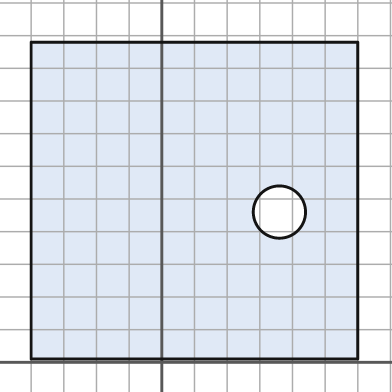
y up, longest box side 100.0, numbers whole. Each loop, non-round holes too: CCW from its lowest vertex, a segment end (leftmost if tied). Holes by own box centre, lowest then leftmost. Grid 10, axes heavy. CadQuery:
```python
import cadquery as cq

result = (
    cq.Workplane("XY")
    .moveTo(-40.0, 1.0)
    .lineTo(60.0, 1.0)
    .lineTo(60.0, 98.0)
    .lineTo(-40.0, 98.0)
    .close()
    .moveTo(36.0, 46.0)
    .circle(8.0)
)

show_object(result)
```